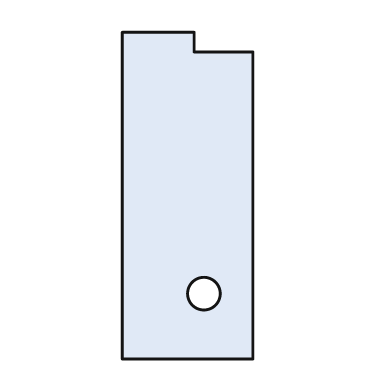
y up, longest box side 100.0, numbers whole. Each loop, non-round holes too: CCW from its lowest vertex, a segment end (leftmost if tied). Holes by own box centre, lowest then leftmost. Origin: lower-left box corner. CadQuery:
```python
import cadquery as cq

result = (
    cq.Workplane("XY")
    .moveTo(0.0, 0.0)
    .lineTo(40.0, 0.0)
    .lineTo(40.0, 94.0)
    .lineTo(22.0, 94.0)
    .lineTo(22.0, 100.0)
    .lineTo(0.0, 100.0)
    .close()
    .moveTo(25.0, 20.0)
    .circle(5.0)
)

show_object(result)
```